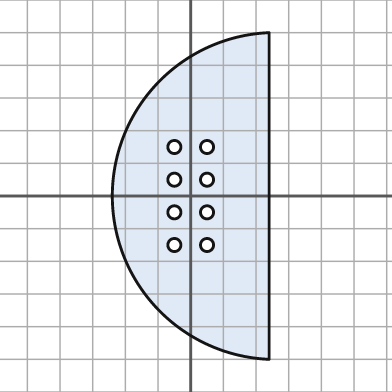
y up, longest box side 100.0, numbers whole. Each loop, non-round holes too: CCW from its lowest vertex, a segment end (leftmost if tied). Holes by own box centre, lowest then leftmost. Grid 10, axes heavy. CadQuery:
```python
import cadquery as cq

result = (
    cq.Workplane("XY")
    .moveTo(24.0, -50.0)
    .lineTo(24.0, 50.0)
    .threePointArc((-24.0, 0.0), (24.0, -50.0))
    .close()
    .moveTo(-5.0, -15.0)
    .circle(2.0)
    .moveTo(5.0, -15.0)
    .circle(2.0)
    .moveTo(-5.0, -5.0)
    .circle(2.0)
    .moveTo(5.0, -5.0)
    .circle(2.0)
    .moveTo(-5.0, 5.0)
    .circle(2.0)
    .moveTo(5.0, 5.0)
    .circle(2.0)
    .moveTo(-5.0, 15.0)
    .circle(2.0)
    .moveTo(5.0, 15.0)
    .circle(2.0)
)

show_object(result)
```